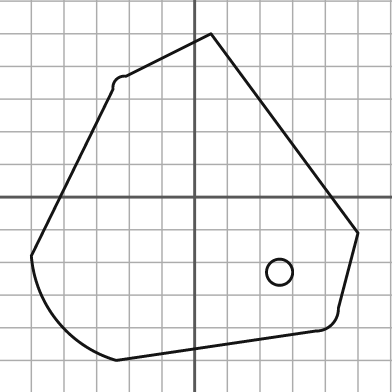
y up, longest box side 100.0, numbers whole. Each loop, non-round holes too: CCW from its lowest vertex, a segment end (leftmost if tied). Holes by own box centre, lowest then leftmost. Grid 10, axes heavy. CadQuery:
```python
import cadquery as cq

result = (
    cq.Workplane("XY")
    .moveTo(-24.0, -50.0)
    .lineTo(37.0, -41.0)
    .threePointArc((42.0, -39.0), (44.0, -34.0))
    .lineTo(50.0, -11.0)
    .lineTo(5.0, 50.0)
    .lineTo(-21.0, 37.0)
    .threePointArc((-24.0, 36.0), (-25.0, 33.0))
    .lineTo(-50.0, -18.0)
    .threePointArc((-42.0, -38.0), (-24.0, -50.0))
    .close()
    .moveTo(26.0, -23.0)
    .circle(4.0)
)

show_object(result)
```